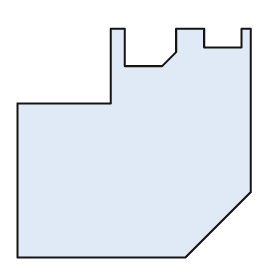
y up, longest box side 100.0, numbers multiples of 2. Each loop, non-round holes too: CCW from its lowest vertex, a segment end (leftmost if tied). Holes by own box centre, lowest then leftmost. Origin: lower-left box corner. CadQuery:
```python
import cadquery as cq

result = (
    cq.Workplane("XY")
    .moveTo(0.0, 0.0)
    .lineTo(72.0, 0.0)
    .lineTo(100.0, 28.0)
    .lineTo(100.0, 98.0)
    .lineTo(96.0, 98.0)
    .lineTo(96.0, 90.0)
    .lineTo(80.0, 90.0)
    .lineTo(80.0, 98.0)
    .lineTo(68.0, 98.0)
    .lineTo(68.0, 88.0)
    .lineTo(62.0, 82.0)
    .lineTo(46.0, 82.0)
    .lineTo(46.0, 98.0)
    .lineTo(40.0, 98.0)
    .lineTo(40.0, 66.0)
    .lineTo(0.0, 66.0)
    .close()
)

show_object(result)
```